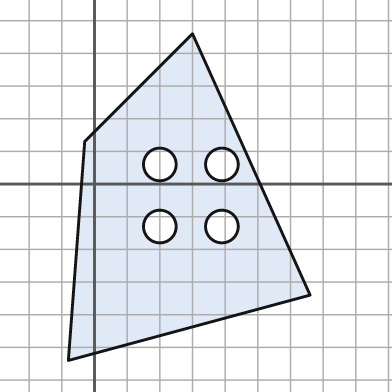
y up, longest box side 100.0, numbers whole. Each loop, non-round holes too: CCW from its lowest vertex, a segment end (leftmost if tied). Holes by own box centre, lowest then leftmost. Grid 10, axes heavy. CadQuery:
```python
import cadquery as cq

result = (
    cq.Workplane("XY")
    .moveTo(-8.0, -54.0)
    .lineTo(66.0, -34.0)
    .lineTo(30.0, 46.0)
    .lineTo(-3.0, 13.0)
    .close()
    .moveTo(20.0, -13.0)
    .circle(5.0)
    .moveTo(39.0, -13.0)
    .circle(5.0)
    .moveTo(20.0, 6.0)
    .circle(5.0)
    .moveTo(39.0, 6.0)
    .circle(5.0)
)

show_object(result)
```